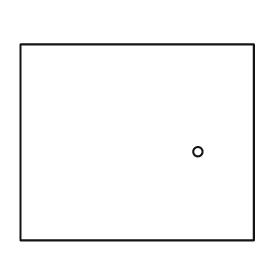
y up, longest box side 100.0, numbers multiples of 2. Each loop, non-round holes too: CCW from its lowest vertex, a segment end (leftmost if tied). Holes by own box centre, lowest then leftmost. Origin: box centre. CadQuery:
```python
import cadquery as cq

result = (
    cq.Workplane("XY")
    .moveTo(-50.0, -42.0)
    .lineTo(50.0, -42.0)
    .lineTo(50.0, 42.0)
    .lineTo(-50.0, 42.0)
    .close()
    .moveTo(26.0, -4.0)
    .circle(2.0)
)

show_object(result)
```